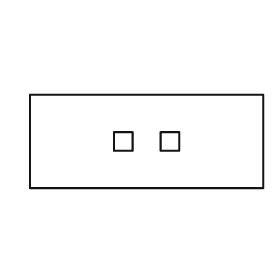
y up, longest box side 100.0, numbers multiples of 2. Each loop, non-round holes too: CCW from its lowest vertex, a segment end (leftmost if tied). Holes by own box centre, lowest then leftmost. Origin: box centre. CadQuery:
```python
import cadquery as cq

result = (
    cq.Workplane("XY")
    .moveTo(-50.0, -20.0)
    .lineTo(50.0, -20.0)
    .lineTo(50.0, 20.0)
    .lineTo(-50.0, 20.0)
    .close()
    .moveTo(-14.0, -4.0)
    .lineTo(-6.0, -4.0)
    .lineTo(-6.0, 4.0)
    .lineTo(-14.0, 4.0)
    .close()
    .moveTo(6.0, -4.0)
    .lineTo(14.0, -4.0)
    .lineTo(14.0, 4.0)
    .lineTo(6.0, 4.0)
    .close()
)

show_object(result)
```